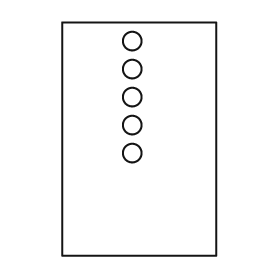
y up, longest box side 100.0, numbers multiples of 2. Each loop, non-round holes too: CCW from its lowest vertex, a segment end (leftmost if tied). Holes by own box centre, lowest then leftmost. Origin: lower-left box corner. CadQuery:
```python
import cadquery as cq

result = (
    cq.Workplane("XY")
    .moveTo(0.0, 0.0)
    .lineTo(66.0, 0.0)
    .lineTo(66.0, 100.0)
    .lineTo(0.0, 100.0)
    .close()
    .moveTo(30.0, 44.0)
    .circle(4.0)
    .moveTo(30.0, 56.0)
    .circle(4.0)
    .moveTo(30.0, 68.0)
    .circle(4.0)
    .moveTo(30.0, 80.0)
    .circle(4.0)
    .moveTo(30.0, 92.0)
    .circle(4.0)
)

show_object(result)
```